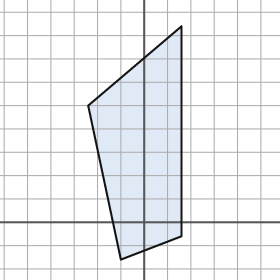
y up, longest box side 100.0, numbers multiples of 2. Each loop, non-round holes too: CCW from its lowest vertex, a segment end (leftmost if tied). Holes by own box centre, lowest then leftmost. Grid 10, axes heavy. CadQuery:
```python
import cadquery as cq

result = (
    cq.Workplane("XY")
    .moveTo(-10.0, -16.0)
    .lineTo(16.0, -6.0)
    .lineTo(16.0, 84.0)
    .lineTo(-24.0, 50.0)
    .close()
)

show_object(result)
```